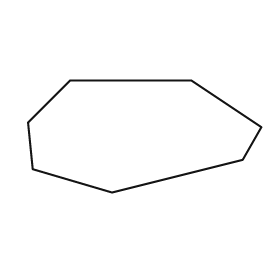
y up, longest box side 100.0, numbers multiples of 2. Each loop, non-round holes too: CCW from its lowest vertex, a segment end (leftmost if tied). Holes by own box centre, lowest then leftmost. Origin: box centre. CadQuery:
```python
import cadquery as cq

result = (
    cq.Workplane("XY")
    .moveTo(-14.0, -24.0)
    .lineTo(42.0, -10.0)
    .lineTo(50.0, 4.0)
    .lineTo(20.0, 24.0)
    .lineTo(-32.0, 24.0)
    .lineTo(-50.0, 6.0)
    .lineTo(-48.0, -14.0)
    .close()
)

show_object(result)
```